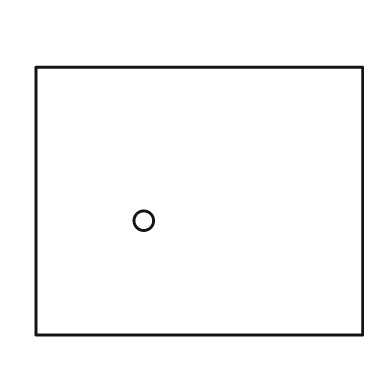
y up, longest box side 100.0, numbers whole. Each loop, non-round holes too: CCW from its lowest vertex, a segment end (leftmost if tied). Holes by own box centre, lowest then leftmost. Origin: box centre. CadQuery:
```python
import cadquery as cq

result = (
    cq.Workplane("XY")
    .moveTo(-50.0, -41.0)
    .lineTo(50.0, -41.0)
    .lineTo(50.0, 41.0)
    .lineTo(-50.0, 41.0)
    .close()
    .moveTo(-17.0, -6.0)
    .circle(3.0)
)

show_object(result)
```